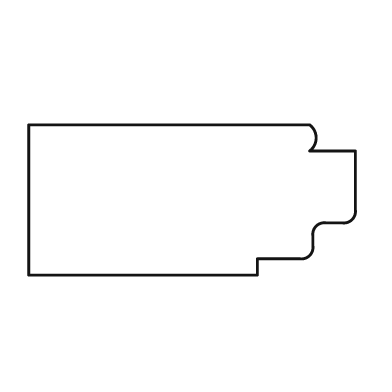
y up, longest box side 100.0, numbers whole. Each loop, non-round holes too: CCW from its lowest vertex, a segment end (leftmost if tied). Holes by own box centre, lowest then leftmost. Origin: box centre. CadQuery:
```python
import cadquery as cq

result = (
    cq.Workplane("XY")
    .moveTo(-50.0, -23.0)
    .lineTo(20.0, -23.0)
    .lineTo(20.0, -18.0)
    .lineTo(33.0, -18.0)
    .threePointArc((36.0, -17.0), (37.0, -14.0))
    .lineTo(37.0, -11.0)
    .threePointArc((38.0, -8.0), (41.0, -7.0))
    .lineTo(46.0, -7.0)
    .threePointArc((49.0, -6.0), (50.0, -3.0))
    .lineTo(50.0, 15.0)
    .lineTo(36.0, 15.0)
    .threePointArc((38.0, 19.0), (36.0, 23.0))
    .lineTo(-50.0, 23.0)
    .close()
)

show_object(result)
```